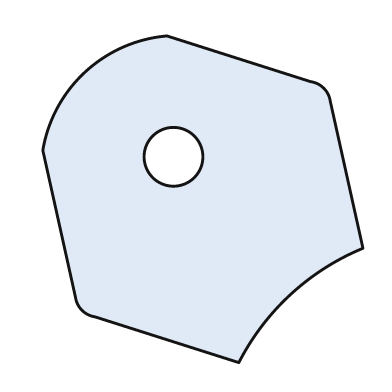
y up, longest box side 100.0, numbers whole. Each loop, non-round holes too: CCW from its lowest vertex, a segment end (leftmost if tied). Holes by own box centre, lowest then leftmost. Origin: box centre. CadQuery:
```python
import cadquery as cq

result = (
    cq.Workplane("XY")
    .moveTo(11.0, -50.0)
    .threePointArc((27.0, -29.0), (49.0, -15.0))
    .lineTo(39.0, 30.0)
    .threePointArc((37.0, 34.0), (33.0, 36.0))
    .lineTo(-11.0, 50.0)
    .threePointArc((-36.0, 39.0), (-49.0, 15.0))
    .lineTo(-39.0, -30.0)
    .threePointArc((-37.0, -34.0), (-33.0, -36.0))
    .close()
    .moveTo(-9.0, 13.0)
    .circle(9.0)
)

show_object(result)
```